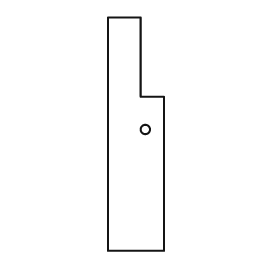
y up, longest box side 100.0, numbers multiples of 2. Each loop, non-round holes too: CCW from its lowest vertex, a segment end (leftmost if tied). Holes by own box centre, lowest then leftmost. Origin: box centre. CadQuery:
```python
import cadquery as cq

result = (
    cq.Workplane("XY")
    .moveTo(-12.0, -50.0)
    .lineTo(12.0, -50.0)
    .lineTo(12.0, 16.0)
    .lineTo(2.0, 16.0)
    .lineTo(2.0, 50.0)
    .lineTo(-12.0, 50.0)
    .close()
    .moveTo(4.0, 2.0)
    .circle(2.0)
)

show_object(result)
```